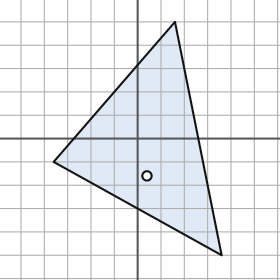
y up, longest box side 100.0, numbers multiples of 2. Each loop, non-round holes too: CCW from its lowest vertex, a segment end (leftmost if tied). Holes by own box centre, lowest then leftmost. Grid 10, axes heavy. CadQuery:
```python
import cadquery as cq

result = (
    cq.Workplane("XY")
    .moveTo(36.0, -50.0)
    .lineTo(16.0, 50.0)
    .lineTo(-36.0, -10.0)
    .close()
    .moveTo(4.0, -16.0)
    .circle(2.0)
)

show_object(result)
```